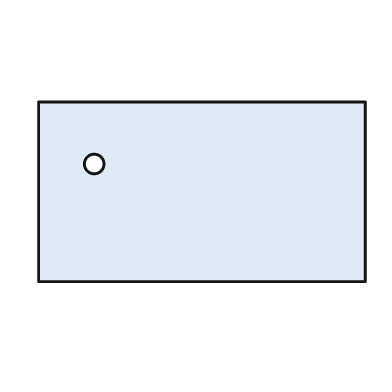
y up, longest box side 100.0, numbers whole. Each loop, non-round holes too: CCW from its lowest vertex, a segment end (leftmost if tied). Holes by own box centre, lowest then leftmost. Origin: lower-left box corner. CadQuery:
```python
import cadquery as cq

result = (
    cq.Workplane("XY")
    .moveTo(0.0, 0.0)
    .lineTo(100.0, 0.0)
    .lineTo(100.0, 55.0)
    .lineTo(0.0, 55.0)
    .close()
    .moveTo(17.0, 36.0)
    .circle(3.0)
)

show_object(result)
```